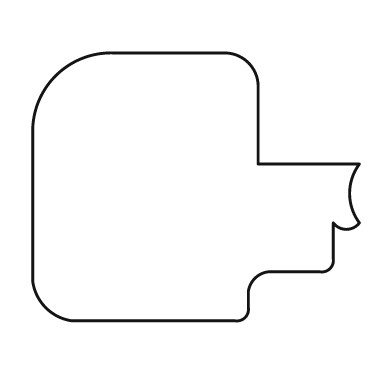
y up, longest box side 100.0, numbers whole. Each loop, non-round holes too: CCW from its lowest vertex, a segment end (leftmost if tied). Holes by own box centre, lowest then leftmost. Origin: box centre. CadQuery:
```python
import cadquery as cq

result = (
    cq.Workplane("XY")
    .moveTo(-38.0, -41.0)
    .lineTo(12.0, -41.0)
    .threePointArc((15.0, -40.0), (16.0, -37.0))
    .lineTo(16.0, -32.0)
    .threePointArc((18.0, -28.0), (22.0, -26.0))
    .lineTo(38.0, -26.0)
    .threePointArc((41.0, -25.0), (42.0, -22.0))
    .lineTo(42.0, -11.0)
    .threePointArc((46.0, -13.0), (50.0, -11.0))
    .threePointArc((47.0, -2.0), (50.0, 7.0))
    .lineTo(19.0, 7.0)
    .lineTo(19.0, 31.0)
    .threePointArc((16.0, 38.0), (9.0, 41.0))
    .lineTo(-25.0, 41.0)
    .threePointArc((-43.0, 34.0), (-50.0, 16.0))
    .lineTo(-50.0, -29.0)
    .threePointArc((-46.0, -37.0), (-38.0, -41.0))
    .close()
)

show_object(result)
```